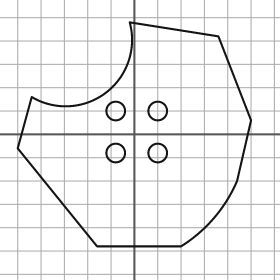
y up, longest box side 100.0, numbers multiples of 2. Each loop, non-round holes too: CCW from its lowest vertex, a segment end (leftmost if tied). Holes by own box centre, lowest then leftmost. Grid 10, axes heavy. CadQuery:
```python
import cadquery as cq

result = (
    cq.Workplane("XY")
    .moveTo(-16.0, -48.0)
    .lineTo(20.0, -48.0)
    .threePointArc((34.0, -36.0), (44.0, -20.0))
    .lineTo(50.0, 6.0)
    .lineTo(36.0, 42.0)
    .lineTo(-2.0, 48.0)
    .threePointArc((-12.0, 18.0), (-44.0, 16.0))
    .lineTo(-50.0, -6.0)
    .close()
    .moveTo(-8.0, -8.0)
    .circle(4.0)
    .moveTo(10.0, -8.0)
    .circle(4.0)
    .moveTo(-8.0, 10.0)
    .circle(4.0)
    .moveTo(10.0, 10.0)
    .circle(4.0)
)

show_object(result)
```